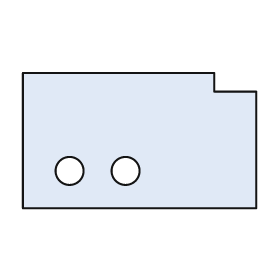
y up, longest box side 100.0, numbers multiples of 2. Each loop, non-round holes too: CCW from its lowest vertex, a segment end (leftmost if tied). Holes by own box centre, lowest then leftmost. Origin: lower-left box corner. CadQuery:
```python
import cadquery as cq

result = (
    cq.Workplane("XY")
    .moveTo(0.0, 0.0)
    .lineTo(100.0, 0.0)
    .lineTo(100.0, 50.0)
    .lineTo(82.0, 50.0)
    .lineTo(82.0, 58.0)
    .lineTo(0.0, 58.0)
    .close()
    .moveTo(20.0, 16.0)
    .circle(6.0)
    .moveTo(44.0, 16.0)
    .circle(6.0)
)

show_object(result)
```